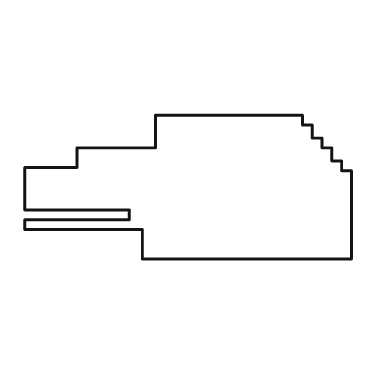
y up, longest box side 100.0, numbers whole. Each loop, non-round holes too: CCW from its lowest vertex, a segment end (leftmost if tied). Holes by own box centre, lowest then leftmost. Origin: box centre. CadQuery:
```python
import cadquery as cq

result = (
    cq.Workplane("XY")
    .moveTo(-14.0, -22.0)
    .lineTo(50.0, -22.0)
    .lineTo(50.0, 5.0)
    .lineTo(47.0, 5.0)
    .lineTo(47.0, 8.0)
    .lineTo(44.0, 8.0)
    .lineTo(44.0, 12.0)
    .lineTo(41.0, 12.0)
    .lineTo(41.0, 15.0)
    .lineTo(38.0, 15.0)
    .lineTo(38.0, 19.0)
    .lineTo(35.0, 19.0)
    .lineTo(35.0, 22.0)
    .lineTo(-10.0, 22.0)
    .lineTo(-10.0, 12.0)
    .lineTo(-34.0, 12.0)
    .lineTo(-34.0, 6.0)
    .lineTo(-50.0, 6.0)
    .lineTo(-50.0, -7.0)
    .lineTo(-18.0, -7.0)
    .lineTo(-18.0, -10.0)
    .lineTo(-50.0, -10.0)
    .lineTo(-50.0, -13.0)
    .lineTo(-14.0, -13.0)
    .close()
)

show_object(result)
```